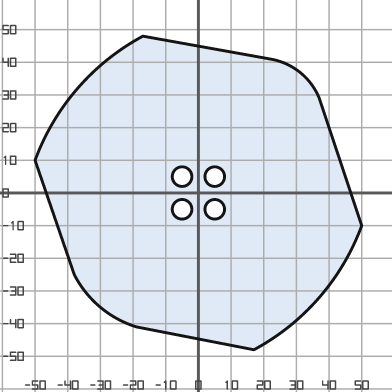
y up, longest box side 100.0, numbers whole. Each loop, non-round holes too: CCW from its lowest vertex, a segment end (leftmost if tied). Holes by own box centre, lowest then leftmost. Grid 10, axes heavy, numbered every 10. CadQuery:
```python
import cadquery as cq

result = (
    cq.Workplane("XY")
    .moveTo(17.0, -48.0)
    .threePointArc((37.0, -32.0), (50.0, -10.0))
    .lineTo(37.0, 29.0)
    .threePointArc((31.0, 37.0), (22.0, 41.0))
    .lineTo(-17.0, 48.0)
    .threePointArc((-37.0, 32.0), (-50.0, 10.0))
    .lineTo(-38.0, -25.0)
    .threePointArc((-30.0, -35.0), (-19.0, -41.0))
    .close()
    .moveTo(-5.0, -5.0)
    .circle(3.0)
    .moveTo(5.0, -5.0)
    .circle(3.0)
    .moveTo(-5.0, 5.0)
    .circle(3.0)
    .moveTo(5.0, 5.0)
    .circle(3.0)
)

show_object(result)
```